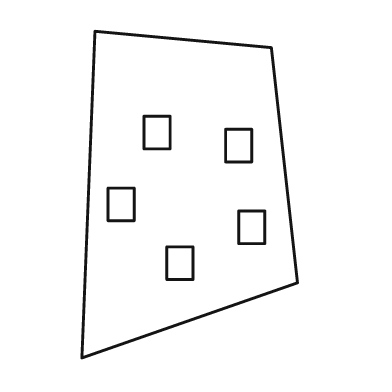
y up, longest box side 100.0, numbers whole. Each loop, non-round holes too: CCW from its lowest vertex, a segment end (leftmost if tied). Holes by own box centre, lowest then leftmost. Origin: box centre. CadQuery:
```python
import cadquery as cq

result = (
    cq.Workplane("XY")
    .moveTo(-33.0, -50.0)
    .lineTo(33.0, -27.0)
    .lineTo(25.0, 45.0)
    .lineTo(-29.0, 50.0)
    .close()
    .moveTo(-7.0, -26.0)
    .lineTo(1.0, -26.0)
    .lineTo(1.0, -16.0)
    .lineTo(-7.0, -16.0)
    .close()
    .moveTo(15.0, -15.0)
    .lineTo(23.0, -15.0)
    .lineTo(23.0, -5.0)
    .lineTo(15.0, -5.0)
    .close()
    .moveTo(-25.0, -8.0)
    .lineTo(-17.0, -8.0)
    .lineTo(-17.0, 2.0)
    .lineTo(-25.0, 2.0)
    .close()
    .moveTo(11.0, 10.0)
    .lineTo(19.0, 10.0)
    .lineTo(19.0, 20.0)
    .lineTo(11.0, 20.0)
    .close()
    .moveTo(-14.0, 14.0)
    .lineTo(-6.0, 14.0)
    .lineTo(-6.0, 24.0)
    .lineTo(-14.0, 24.0)
    .close()
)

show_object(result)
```